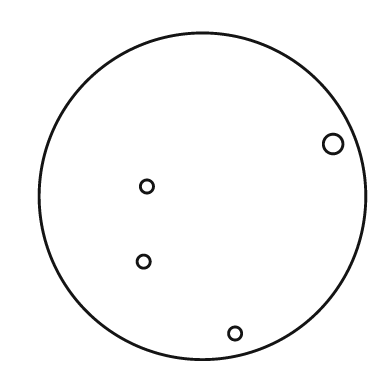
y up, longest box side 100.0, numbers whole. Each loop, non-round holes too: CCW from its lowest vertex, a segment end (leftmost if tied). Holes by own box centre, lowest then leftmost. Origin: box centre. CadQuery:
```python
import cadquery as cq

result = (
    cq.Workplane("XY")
    .moveTo(0.0, 0.0)
    .circle(50.0)
    .moveTo(10.0, -42.0)
    .circle(2.0)
    .moveTo(-18.0, -20.0)
    .circle(2.0)
    .moveTo(-17.0, 3.0)
    .circle(2.0)
    .moveTo(40.0, 16.0)
    .circle(3.0)
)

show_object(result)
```